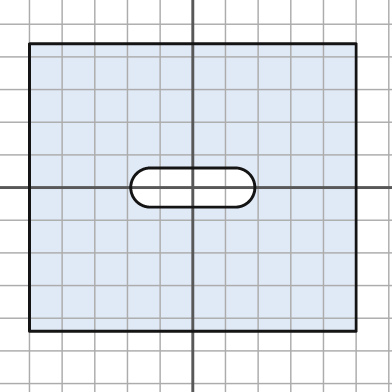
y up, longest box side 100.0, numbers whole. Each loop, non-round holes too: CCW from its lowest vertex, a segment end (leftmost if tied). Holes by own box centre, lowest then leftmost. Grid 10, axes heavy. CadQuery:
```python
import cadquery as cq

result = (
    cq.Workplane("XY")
    .moveTo(-50.0, -44.0)
    .lineTo(50.0, -44.0)
    .lineTo(50.0, 44.0)
    .lineTo(-50.0, 44.0)
    .close()
    .moveTo(-13.0, -6.0)
    .lineTo(13.0, -6.0)
    .threePointArc((19.0, 0.0), (13.0, 6.0))
    .lineTo(-13.0, 6.0)
    .threePointArc((-19.0, 0.0), (-13.0, -6.0))
    .close()
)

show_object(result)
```